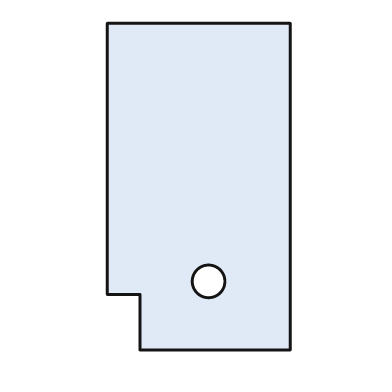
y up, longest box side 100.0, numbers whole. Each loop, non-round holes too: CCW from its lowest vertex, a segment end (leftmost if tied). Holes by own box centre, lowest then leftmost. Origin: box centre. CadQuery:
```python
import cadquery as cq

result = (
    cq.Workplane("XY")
    .moveTo(-18.0, -50.0)
    .lineTo(28.0, -50.0)
    .lineTo(28.0, 50.0)
    .lineTo(-28.0, 50.0)
    .lineTo(-28.0, -33.0)
    .lineTo(-18.0, -33.0)
    .close()
    .moveTo(3.0, -29.0)
    .circle(5.0)
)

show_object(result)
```